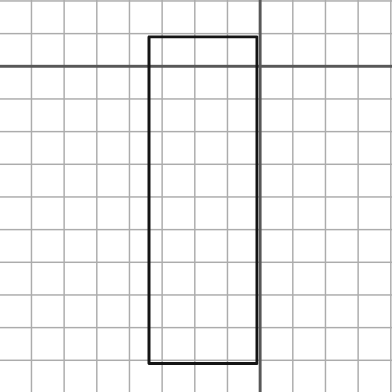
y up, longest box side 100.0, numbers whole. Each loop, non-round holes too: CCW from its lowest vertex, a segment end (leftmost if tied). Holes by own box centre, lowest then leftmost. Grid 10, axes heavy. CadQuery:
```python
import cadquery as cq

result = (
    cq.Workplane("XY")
    .moveTo(-34.0, -91.0)
    .lineTo(-1.0, -91.0)
    .lineTo(-1.0, 9.0)
    .lineTo(-34.0, 9.0)
    .close()
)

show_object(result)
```